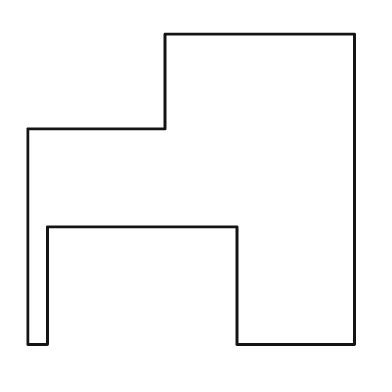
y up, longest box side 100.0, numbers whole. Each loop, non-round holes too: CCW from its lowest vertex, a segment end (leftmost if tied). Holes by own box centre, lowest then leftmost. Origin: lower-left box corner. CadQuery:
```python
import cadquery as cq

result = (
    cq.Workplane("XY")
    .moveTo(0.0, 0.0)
    .lineTo(6.0, 0.0)
    .lineTo(6.0, 36.0)
    .lineTo(64.0, 36.0)
    .lineTo(64.0, 0.0)
    .lineTo(100.0, 0.0)
    .lineTo(100.0, 95.0)
    .lineTo(42.0, 95.0)
    .lineTo(42.0, 66.0)
    .lineTo(0.0, 66.0)
    .close()
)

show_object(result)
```